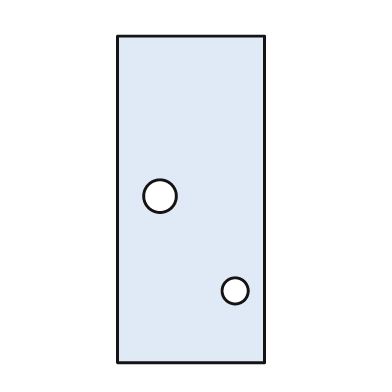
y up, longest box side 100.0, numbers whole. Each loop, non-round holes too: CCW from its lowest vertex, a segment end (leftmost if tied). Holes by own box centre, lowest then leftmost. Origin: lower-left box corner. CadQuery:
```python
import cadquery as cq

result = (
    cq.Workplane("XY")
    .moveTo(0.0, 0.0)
    .lineTo(45.0, 0.0)
    .lineTo(45.0, 100.0)
    .lineTo(0.0, 100.0)
    .close()
    .moveTo(36.0, 22.0)
    .circle(4.0)
    .moveTo(13.0, 51.0)
    .circle(5.0)
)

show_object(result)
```